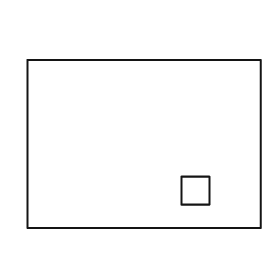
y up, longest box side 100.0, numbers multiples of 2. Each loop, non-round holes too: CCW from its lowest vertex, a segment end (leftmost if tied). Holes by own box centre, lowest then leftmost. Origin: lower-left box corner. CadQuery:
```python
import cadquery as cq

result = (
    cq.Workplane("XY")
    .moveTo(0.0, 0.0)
    .lineTo(100.0, 0.0)
    .lineTo(100.0, 72.0)
    .lineTo(0.0, 72.0)
    .close()
    .moveTo(66.0, 10.0)
    .lineTo(78.0, 10.0)
    .lineTo(78.0, 22.0)
    .lineTo(66.0, 22.0)
    .close()
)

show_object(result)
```